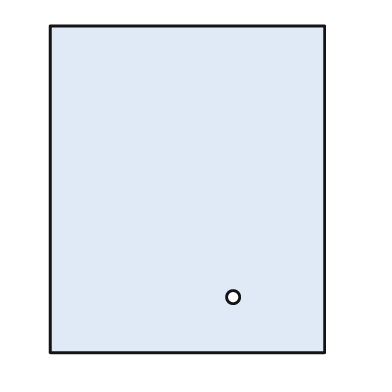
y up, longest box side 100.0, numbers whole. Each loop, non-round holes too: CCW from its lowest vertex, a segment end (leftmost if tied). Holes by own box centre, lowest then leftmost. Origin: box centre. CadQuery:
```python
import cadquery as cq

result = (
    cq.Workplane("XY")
    .moveTo(-42.0, -50.0)
    .lineTo(42.0, -50.0)
    .lineTo(42.0, 50.0)
    .lineTo(-42.0, 50.0)
    .close()
    .moveTo(14.0, -33.0)
    .circle(2.0)
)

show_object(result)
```